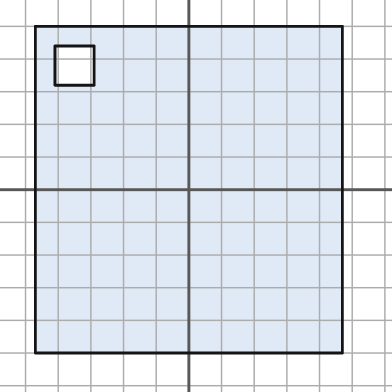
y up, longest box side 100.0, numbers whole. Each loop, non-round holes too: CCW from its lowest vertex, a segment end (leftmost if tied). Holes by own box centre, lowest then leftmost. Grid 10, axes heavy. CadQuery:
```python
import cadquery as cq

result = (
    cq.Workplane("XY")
    .moveTo(-47.0, -50.0)
    .lineTo(47.0, -50.0)
    .lineTo(47.0, 50.0)
    .lineTo(-47.0, 50.0)
    .close()
    .moveTo(-41.0, 32.0)
    .lineTo(-29.0, 32.0)
    .lineTo(-29.0, 44.0)
    .lineTo(-41.0, 44.0)
    .close()
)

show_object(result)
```